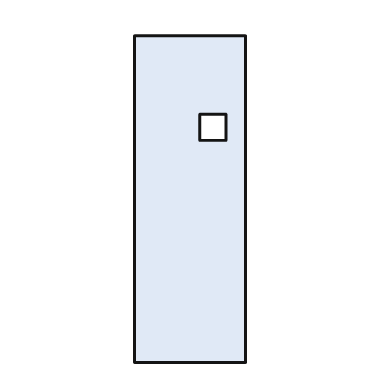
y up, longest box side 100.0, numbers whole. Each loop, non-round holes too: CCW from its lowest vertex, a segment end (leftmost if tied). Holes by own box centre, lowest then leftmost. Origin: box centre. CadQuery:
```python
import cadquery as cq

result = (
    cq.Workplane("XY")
    .moveTo(-17.0, -50.0)
    .lineTo(17.0, -50.0)
    .lineTo(17.0, 50.0)
    .lineTo(-17.0, 50.0)
    .close()
    .moveTo(3.0, 18.0)
    .lineTo(11.0, 18.0)
    .lineTo(11.0, 26.0)
    .lineTo(3.0, 26.0)
    .close()
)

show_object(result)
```